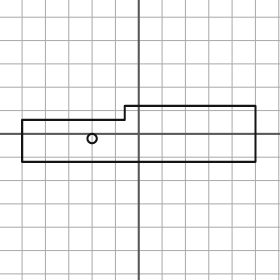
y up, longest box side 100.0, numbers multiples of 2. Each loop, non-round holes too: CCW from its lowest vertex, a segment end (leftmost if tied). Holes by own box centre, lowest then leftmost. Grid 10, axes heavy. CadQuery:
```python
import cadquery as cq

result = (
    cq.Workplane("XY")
    .moveTo(-50.0, -12.0)
    .lineTo(50.0, -12.0)
    .lineTo(50.0, 12.0)
    .lineTo(-6.0, 12.0)
    .lineTo(-6.0, 6.0)
    .lineTo(-50.0, 6.0)
    .close()
    .moveTo(-20.0, -2.0)
    .circle(2.0)
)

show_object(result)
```